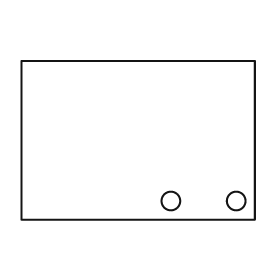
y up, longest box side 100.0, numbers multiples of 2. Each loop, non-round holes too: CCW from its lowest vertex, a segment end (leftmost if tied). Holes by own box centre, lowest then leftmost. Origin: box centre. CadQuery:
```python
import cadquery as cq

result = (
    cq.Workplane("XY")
    .moveTo(-50.0, -34.0)
    .lineTo(50.0, -34.0)
    .lineTo(50.0, 34.0)
    .lineTo(-50.0, 34.0)
    .close()
    .moveTo(14.0, -26.0)
    .circle(4.0)
    .moveTo(42.0, -26.0)
    .circle(4.0)
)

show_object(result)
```